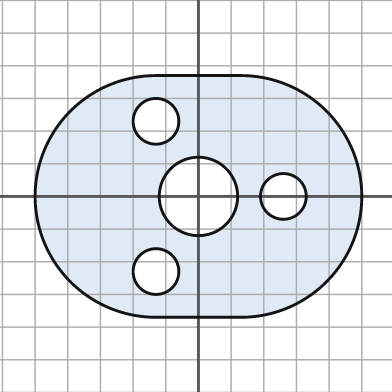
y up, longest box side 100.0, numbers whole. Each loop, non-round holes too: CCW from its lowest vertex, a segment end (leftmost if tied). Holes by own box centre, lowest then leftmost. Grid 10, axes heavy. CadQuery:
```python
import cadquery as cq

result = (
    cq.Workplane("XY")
    .moveTo(-13.0, -37.0)
    .lineTo(13.0, -37.0)
    .threePointArc((50.0, 0.0), (13.0, 37.0))
    .lineTo(-13.0, 37.0)
    .threePointArc((-50.0, 0.0), (-13.0, -37.0))
    .close()
    .moveTo(-13.0, -23.0)
    .circle(7.0)
    .moveTo(0.0, 0.0)
    .circle(12.0)
    .moveTo(26.0, 0.0)
    .circle(7.0)
    .moveTo(-13.0, 23.0)
    .circle(7.0)
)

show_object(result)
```